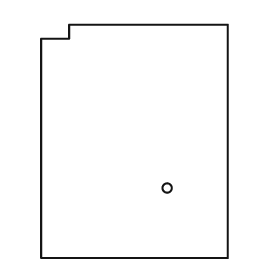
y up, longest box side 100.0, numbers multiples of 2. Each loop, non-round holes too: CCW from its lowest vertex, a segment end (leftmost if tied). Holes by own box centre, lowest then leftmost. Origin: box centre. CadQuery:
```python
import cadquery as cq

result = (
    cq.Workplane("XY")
    .moveTo(-40.0, -50.0)
    .lineTo(40.0, -50.0)
    .lineTo(40.0, 50.0)
    .lineTo(-28.0, 50.0)
    .lineTo(-28.0, 44.0)
    .lineTo(-40.0, 44.0)
    .close()
    .moveTo(14.0, -20.0)
    .circle(2.0)
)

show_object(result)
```